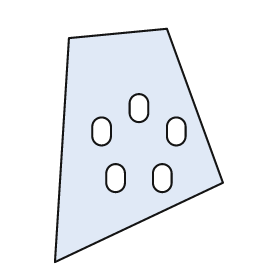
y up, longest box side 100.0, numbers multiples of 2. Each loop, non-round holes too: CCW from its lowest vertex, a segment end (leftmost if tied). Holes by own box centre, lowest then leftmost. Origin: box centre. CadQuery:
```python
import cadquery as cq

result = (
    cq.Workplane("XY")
    .moveTo(-36.0, -50.0)
    .lineTo(36.0, -16.0)
    .lineTo(12.0, 50.0)
    .lineTo(-30.0, 46.0)
    .close()
    .moveTo(-14.0, -16.0)
    .threePointArc((-10.0, -20.0), (-6.0, -16.0))
    .lineTo(-6.0, -12.0)
    .threePointArc((-10.0, -8.0), (-14.0, -12.0))
    .close()
    .moveTo(6.0, -16.0)
    .threePointArc((10.0, -20.0), (14.0, -16.0))
    .lineTo(14.0, -12.0)
    .threePointArc((10.0, -8.0), (6.0, -12.0))
    .close()
    .moveTo(-20.0, 4.0)
    .threePointArc((-16.0, 0.0), (-12.0, 4.0))
    .lineTo(-12.0, 8.0)
    .threePointArc((-16.0, 12.0), (-20.0, 8.0))
    .close()
    .moveTo(12.0, 4.0)
    .threePointArc((16.0, 0.0), (20.0, 4.0))
    .lineTo(20.0, 8.0)
    .threePointArc((16.0, 12.0), (12.0, 8.0))
    .close()
    .moveTo(-4.0, 14.0)
    .threePointArc((0.0, 10.0), (4.0, 14.0))
    .lineTo(4.0, 18.0)
    .threePointArc((0.0, 22.0), (-4.0, 18.0))
    .close()
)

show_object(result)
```